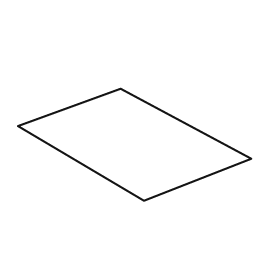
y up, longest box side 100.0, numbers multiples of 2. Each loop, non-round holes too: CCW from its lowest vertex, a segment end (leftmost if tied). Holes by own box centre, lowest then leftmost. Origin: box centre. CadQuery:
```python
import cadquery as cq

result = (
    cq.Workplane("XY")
    .moveTo(4.0, -24.0)
    .lineTo(50.0, -6.0)
    .lineTo(-6.0, 24.0)
    .lineTo(-50.0, 8.0)
    .close()
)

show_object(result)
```